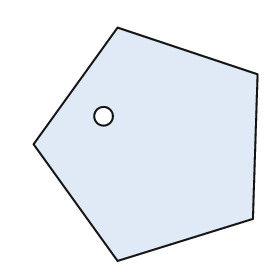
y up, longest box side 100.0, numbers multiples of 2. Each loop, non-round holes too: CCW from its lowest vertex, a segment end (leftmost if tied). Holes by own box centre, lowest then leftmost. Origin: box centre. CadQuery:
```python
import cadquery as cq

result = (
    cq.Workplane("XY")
    .moveTo(-12.0, -50.0)
    .lineTo(46.0, -32.0)
    .lineTo(48.0, 30.0)
    .lineTo(-12.0, 50.0)
    .lineTo(-48.0, 0.0)
    .close()
    .moveTo(-18.0, 12.0)
    .circle(4.0)
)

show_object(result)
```